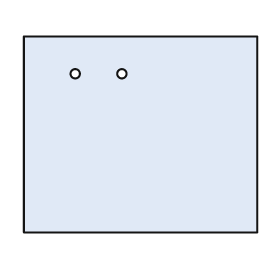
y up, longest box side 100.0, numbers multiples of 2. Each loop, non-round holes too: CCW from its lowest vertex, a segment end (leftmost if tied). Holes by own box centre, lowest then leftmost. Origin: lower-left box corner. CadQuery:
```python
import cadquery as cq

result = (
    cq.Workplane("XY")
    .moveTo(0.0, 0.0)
    .lineTo(100.0, 0.0)
    .lineTo(100.0, 84.0)
    .lineTo(0.0, 84.0)
    .close()
    .moveTo(22.0, 68.0)
    .circle(2.0)
    .moveTo(42.0, 68.0)
    .circle(2.0)
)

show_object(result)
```